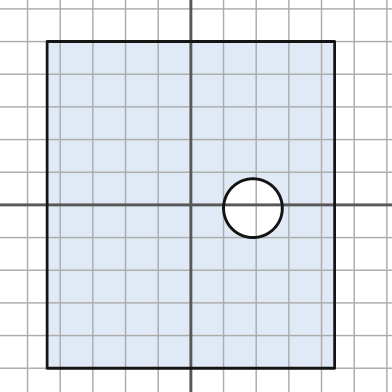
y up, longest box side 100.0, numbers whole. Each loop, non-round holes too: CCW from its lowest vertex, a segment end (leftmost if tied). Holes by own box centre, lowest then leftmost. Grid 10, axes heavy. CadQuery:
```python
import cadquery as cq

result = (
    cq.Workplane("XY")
    .moveTo(-44.0, -50.0)
    .lineTo(44.0, -50.0)
    .lineTo(44.0, 50.0)
    .lineTo(-44.0, 50.0)
    .close()
    .moveTo(19.0, -1.0)
    .circle(9.0)
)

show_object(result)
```